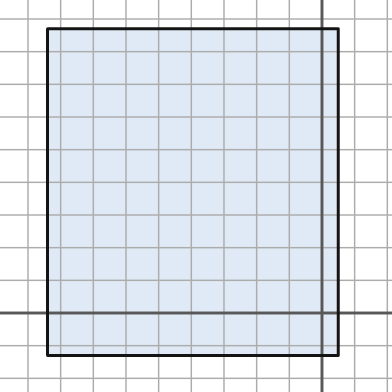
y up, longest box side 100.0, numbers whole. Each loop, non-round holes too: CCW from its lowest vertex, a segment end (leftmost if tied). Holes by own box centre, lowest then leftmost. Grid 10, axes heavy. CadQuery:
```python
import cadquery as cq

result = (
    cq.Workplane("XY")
    .moveTo(-84.0, -13.0)
    .lineTo(5.0, -13.0)
    .lineTo(5.0, 87.0)
    .lineTo(-84.0, 87.0)
    .close()
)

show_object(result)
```